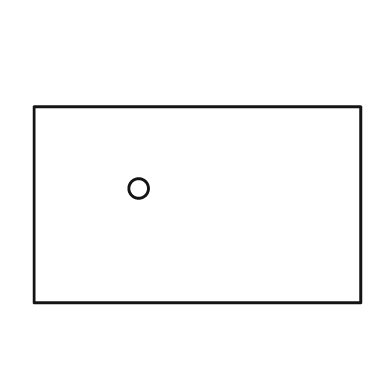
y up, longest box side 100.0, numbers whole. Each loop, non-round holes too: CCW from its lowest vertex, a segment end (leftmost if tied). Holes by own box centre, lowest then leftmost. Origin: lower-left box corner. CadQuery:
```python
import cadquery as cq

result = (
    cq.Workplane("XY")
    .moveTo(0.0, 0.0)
    .lineTo(100.0, 0.0)
    .lineTo(100.0, 60.0)
    .lineTo(0.0, 60.0)
    .close()
    .moveTo(32.0, 35.0)
    .circle(3.0)
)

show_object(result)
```